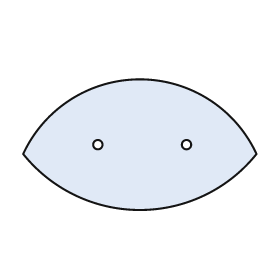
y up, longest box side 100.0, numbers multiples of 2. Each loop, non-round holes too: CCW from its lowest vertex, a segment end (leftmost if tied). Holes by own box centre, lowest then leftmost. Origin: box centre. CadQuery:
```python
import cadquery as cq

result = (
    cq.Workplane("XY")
    .moveTo(-50.0, -4.0)
    .threePointArc((0.0, -28.0), (50.0, -4.0))
    .threePointArc((0.0, 28.0), (-50.0, -4.0))
    .close()
    .moveTo(-18.0, 0.0)
    .circle(2.0)
    .moveTo(20.0, 0.0)
    .circle(2.0)
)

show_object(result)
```